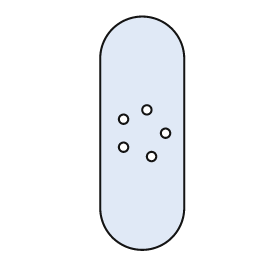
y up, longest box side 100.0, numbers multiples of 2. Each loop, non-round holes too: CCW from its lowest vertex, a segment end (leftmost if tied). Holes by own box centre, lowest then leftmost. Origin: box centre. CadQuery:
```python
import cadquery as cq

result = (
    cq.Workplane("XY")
    .moveTo(-18.0, -32.0)
    .threePointArc((0.0, -50.0), (18.0, -32.0))
    .lineTo(18.0, 32.0)
    .threePointArc((0.0, 50.0), (-18.0, 32.0))
    .close()
    .moveTo(4.0, -10.0)
    .circle(2.0)
    .moveTo(-8.0, -6.0)
    .circle(2.0)
    .moveTo(10.0, 0.0)
    .circle(2.0)
    .moveTo(-8.0, 6.0)
    .circle(2.0)
    .moveTo(2.0, 10.0)
    .circle(2.0)
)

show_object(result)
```